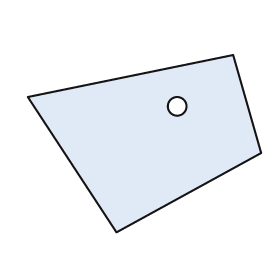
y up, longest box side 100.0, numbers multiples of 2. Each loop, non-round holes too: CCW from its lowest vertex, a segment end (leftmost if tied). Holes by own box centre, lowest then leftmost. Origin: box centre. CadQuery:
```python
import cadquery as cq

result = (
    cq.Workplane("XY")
    .moveTo(-12.0, -38.0)
    .lineTo(50.0, -4.0)
    .lineTo(38.0, 38.0)
    .lineTo(-50.0, 20.0)
    .close()
    .moveTo(14.0, 16.0)
    .circle(4.0)
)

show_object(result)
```